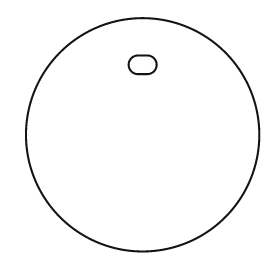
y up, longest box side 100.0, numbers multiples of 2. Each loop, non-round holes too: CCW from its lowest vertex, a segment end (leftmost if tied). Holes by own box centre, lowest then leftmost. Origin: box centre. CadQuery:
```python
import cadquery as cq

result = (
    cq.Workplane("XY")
    .moveTo(0.0, 0.0)
    .circle(50.0)
    .moveTo(-2.0, 26.0)
    .lineTo(2.0, 26.0)
    .threePointArc((6.0, 30.0), (2.0, 34.0))
    .lineTo(-2.0, 34.0)
    .threePointArc((-6.0, 30.0), (-2.0, 26.0))
    .close()
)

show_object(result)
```